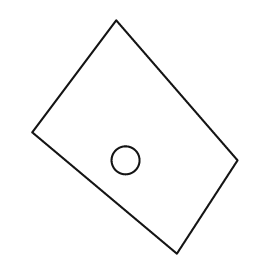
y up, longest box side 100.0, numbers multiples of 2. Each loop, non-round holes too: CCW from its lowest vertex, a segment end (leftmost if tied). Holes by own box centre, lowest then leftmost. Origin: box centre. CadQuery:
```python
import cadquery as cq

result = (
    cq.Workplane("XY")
    .moveTo(18.0, -50.0)
    .lineTo(44.0, -10.0)
    .lineTo(-8.0, 50.0)
    .lineTo(-44.0, 2.0)
    .close()
    .moveTo(-4.0, -10.0)
    .circle(6.0)
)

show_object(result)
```